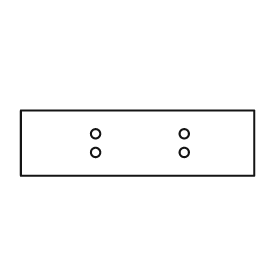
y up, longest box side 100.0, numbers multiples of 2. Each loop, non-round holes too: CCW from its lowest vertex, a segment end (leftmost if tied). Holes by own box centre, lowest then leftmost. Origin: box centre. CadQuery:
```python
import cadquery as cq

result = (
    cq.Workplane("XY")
    .moveTo(-50.0, -14.0)
    .lineTo(50.0, -14.0)
    .lineTo(50.0, 14.0)
    .lineTo(-50.0, 14.0)
    .close()
    .moveTo(-18.0, -4.0)
    .circle(2.0)
    .moveTo(20.0, -4.0)
    .circle(2.0)
    .moveTo(-18.0, 4.0)
    .circle(2.0)
    .moveTo(20.0, 4.0)
    .circle(2.0)
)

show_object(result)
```